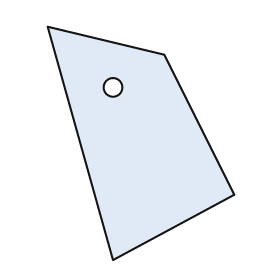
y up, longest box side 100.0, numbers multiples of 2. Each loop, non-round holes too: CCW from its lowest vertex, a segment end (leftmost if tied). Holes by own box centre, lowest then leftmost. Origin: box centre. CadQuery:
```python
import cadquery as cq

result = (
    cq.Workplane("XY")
    .moveTo(-12.0, -50.0)
    .lineTo(40.0, -22.0)
    .lineTo(10.0, 38.0)
    .lineTo(-40.0, 50.0)
    .close()
    .moveTo(-12.0, 24.0)
    .circle(4.0)
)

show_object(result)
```